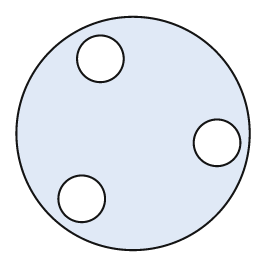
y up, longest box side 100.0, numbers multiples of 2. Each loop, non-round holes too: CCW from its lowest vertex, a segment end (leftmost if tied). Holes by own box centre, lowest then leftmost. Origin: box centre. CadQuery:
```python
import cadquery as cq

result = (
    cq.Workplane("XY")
    .moveTo(0.0, 0.0)
    .circle(50.0)
    .moveTo(-22.0, -28.0)
    .circle(10.0)
    .moveTo(36.0, -4.0)
    .circle(10.0)
    .moveTo(-14.0, 32.0)
    .circle(10.0)
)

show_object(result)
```